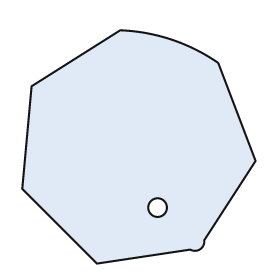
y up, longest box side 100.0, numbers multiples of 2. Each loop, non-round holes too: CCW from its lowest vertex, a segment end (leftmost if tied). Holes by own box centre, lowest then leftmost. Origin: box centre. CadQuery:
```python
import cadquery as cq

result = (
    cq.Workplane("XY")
    .moveTo(-18.0, -50.0)
    .lineTo(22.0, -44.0)
    .threePointArc((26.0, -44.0), (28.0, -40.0))
    .lineTo(50.0, -6.0)
    .lineTo(34.0, 36.0)
    .threePointArc((14.0, 46.0), (-8.0, 50.0))
    .lineTo(-46.0, 26.0)
    .lineTo(-50.0, -18.0)
    .close()
    .moveTo(8.0, -26.0)
    .circle(4.0)
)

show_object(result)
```